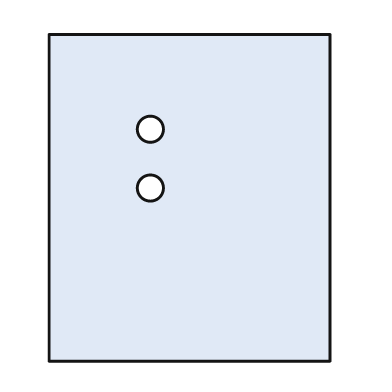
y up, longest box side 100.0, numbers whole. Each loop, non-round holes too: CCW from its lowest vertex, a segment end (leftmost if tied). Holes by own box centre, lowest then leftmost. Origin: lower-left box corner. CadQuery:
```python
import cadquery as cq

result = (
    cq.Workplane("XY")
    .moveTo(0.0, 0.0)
    .lineTo(86.0, 0.0)
    .lineTo(86.0, 100.0)
    .lineTo(0.0, 100.0)
    .close()
    .moveTo(31.0, 53.0)
    .circle(4.0)
    .moveTo(31.0, 71.0)
    .circle(4.0)
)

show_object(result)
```